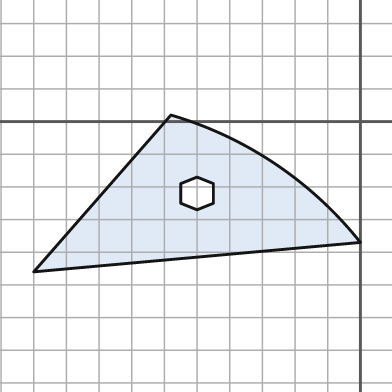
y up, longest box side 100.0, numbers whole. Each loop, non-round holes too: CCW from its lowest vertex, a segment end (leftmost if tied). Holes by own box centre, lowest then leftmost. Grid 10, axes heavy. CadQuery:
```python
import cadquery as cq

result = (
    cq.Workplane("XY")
    .moveTo(-100.0, -46.0)
    .lineTo(0.0, -37.0)
    .threePointArc((-26.0, -13.0), (-58.0, 2.0))
    .close()
    .moveTo(-50.0, -27.0)
    .lineTo(-45.0, -25.0)
    .lineTo(-45.0, -19.0)
    .lineTo(-50.0, -17.0)
    .lineTo(-55.0, -19.0)
    .lineTo(-55.0, -25.0)
    .close()
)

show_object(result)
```